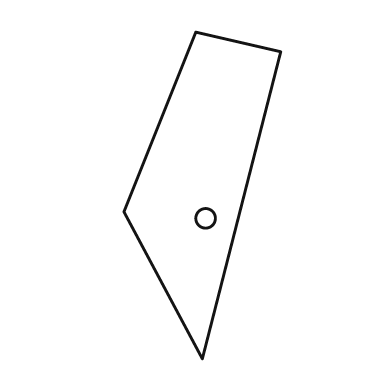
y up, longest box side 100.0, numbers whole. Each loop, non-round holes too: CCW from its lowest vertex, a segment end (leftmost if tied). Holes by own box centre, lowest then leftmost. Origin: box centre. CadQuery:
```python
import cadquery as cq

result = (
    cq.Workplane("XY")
    .moveTo(0.0, -50.0)
    .lineTo(24.0, 44.0)
    .lineTo(-2.0, 50.0)
    .lineTo(-24.0, -5.0)
    .close()
    .moveTo(1.0, -7.0)
    .circle(3.0)
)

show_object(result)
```